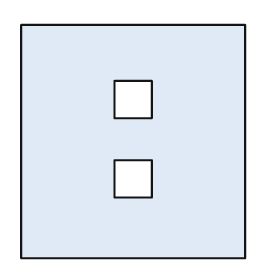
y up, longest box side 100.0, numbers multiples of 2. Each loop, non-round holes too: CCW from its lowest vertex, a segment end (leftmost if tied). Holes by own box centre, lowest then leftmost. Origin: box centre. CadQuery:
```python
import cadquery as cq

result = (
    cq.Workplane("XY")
    .moveTo(-48.0, -50.0)
    .lineTo(48.0, -50.0)
    .lineTo(48.0, 50.0)
    .lineTo(-48.0, 50.0)
    .close()
    .moveTo(-8.0, -24.0)
    .lineTo(8.0, -24.0)
    .lineTo(8.0, -8.0)
    .lineTo(-8.0, -8.0)
    .close()
    .moveTo(-8.0, 10.0)
    .lineTo(8.0, 10.0)
    .lineTo(8.0, 26.0)
    .lineTo(-8.0, 26.0)
    .close()
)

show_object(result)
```